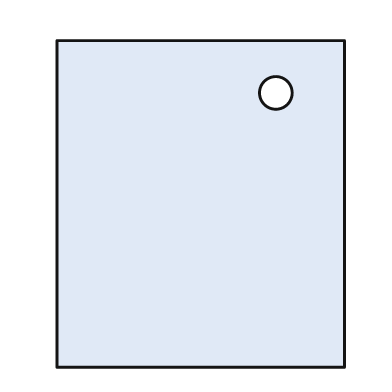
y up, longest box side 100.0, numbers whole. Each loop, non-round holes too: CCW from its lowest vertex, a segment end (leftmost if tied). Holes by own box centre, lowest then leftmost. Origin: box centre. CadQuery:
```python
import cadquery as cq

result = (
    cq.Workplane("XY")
    .moveTo(-44.0, -50.0)
    .lineTo(44.0, -50.0)
    .lineTo(44.0, 50.0)
    .lineTo(-44.0, 50.0)
    .close()
    .moveTo(23.0, 34.0)
    .circle(5.0)
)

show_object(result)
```